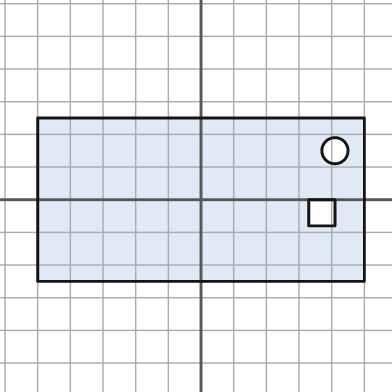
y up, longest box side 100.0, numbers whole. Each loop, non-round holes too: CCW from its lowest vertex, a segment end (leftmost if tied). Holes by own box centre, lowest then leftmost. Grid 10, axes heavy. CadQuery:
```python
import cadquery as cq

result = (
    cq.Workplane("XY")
    .moveTo(-50.0, -25.0)
    .lineTo(50.0, -25.0)
    .lineTo(50.0, 25.0)
    .lineTo(-50.0, 25.0)
    .close()
    .moveTo(33.0, -8.0)
    .lineTo(41.0, -8.0)
    .lineTo(41.0, 0.0)
    .lineTo(33.0, 0.0)
    .close()
    .moveTo(41.0, 15.0)
    .circle(4.0)
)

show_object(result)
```